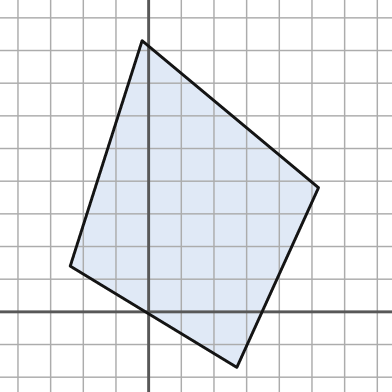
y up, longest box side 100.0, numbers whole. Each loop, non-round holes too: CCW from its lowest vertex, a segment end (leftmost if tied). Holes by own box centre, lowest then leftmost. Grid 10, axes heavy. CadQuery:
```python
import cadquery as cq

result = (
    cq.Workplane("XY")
    .moveTo(27.0, -17.0)
    .lineTo(52.0, 38.0)
    .lineTo(-2.0, 83.0)
    .lineTo(-24.0, 14.0)
    .close()
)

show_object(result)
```